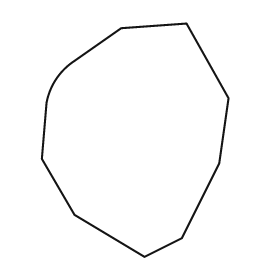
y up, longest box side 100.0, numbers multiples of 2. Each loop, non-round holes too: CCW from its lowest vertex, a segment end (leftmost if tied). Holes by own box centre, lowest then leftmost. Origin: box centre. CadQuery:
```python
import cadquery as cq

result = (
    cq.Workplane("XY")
    .moveTo(4.0, -50.0)
    .lineTo(20.0, -42.0)
    .lineTo(36.0, -10.0)
    .lineTo(40.0, 18.0)
    .lineTo(22.0, 50.0)
    .lineTo(-6.0, 48.0)
    .lineTo(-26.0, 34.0)
    .threePointArc((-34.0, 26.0), (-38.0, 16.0))
    .lineTo(-40.0, -8.0)
    .lineTo(-26.0, -32.0)
    .close()
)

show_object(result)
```